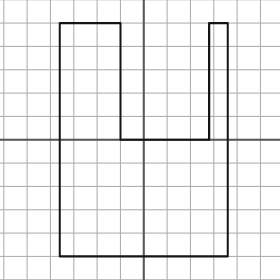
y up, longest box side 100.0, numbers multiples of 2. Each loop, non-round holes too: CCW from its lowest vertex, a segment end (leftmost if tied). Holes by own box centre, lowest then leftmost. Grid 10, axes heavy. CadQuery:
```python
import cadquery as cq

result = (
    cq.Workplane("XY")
    .moveTo(-36.0, -50.0)
    .lineTo(36.0, -50.0)
    .lineTo(36.0, 50.0)
    .lineTo(28.0, 50.0)
    .lineTo(28.0, 0.0)
    .lineTo(-10.0, 0.0)
    .lineTo(-10.0, 50.0)
    .lineTo(-36.0, 50.0)
    .close()
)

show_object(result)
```